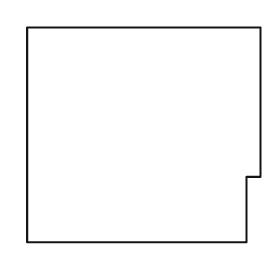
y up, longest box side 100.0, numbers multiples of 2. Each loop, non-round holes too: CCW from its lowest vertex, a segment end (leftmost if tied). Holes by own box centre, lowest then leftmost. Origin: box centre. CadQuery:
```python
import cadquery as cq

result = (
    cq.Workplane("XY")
    .moveTo(-50.0, -46.0)
    .lineTo(44.0, -46.0)
    .lineTo(44.0, -18.0)
    .lineTo(50.0, -18.0)
    .lineTo(50.0, 46.0)
    .lineTo(-50.0, 46.0)
    .close()
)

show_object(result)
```